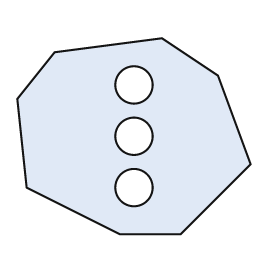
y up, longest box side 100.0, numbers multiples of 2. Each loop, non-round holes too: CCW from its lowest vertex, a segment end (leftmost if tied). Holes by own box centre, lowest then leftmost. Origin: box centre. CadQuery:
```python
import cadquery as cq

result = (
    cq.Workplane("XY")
    .moveTo(-6.0, -42.0)
    .lineTo(20.0, -42.0)
    .lineTo(50.0, -12.0)
    .lineTo(36.0, 26.0)
    .lineTo(12.0, 42.0)
    .lineTo(-34.0, 36.0)
    .lineTo(-50.0, 16.0)
    .lineTo(-46.0, -22.0)
    .close()
    .moveTo(0.0, -22.0)
    .circle(8.0)
    .moveTo(0.0, 0.0)
    .circle(8.0)
    .moveTo(0.0, 22.0)
    .circle(8.0)
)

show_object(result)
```